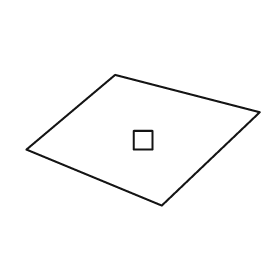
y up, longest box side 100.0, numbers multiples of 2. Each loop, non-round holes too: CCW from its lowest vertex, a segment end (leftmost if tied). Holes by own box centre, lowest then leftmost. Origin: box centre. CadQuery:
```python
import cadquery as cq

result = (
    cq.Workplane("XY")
    .moveTo(8.0, -28.0)
    .lineTo(50.0, 12.0)
    .lineTo(-12.0, 28.0)
    .lineTo(-50.0, -4.0)
    .close()
    .moveTo(-4.0, -4.0)
    .lineTo(4.0, -4.0)
    .lineTo(4.0, 4.0)
    .lineTo(-4.0, 4.0)
    .close()
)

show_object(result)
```